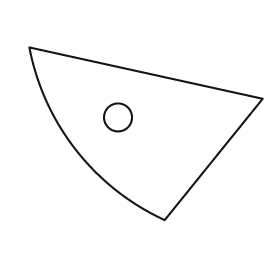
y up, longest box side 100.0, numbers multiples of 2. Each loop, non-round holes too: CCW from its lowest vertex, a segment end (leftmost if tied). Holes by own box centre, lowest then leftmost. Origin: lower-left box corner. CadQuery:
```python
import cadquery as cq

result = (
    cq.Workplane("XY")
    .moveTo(58.0, 0.0)
    .lineTo(100.0, 52.0)
    .lineTo(0.0, 74.0)
    .threePointArc((20.0, 30.0), (58.0, 0.0))
    .close()
    .moveTo(38.0, 44.0)
    .circle(6.0)
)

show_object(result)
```